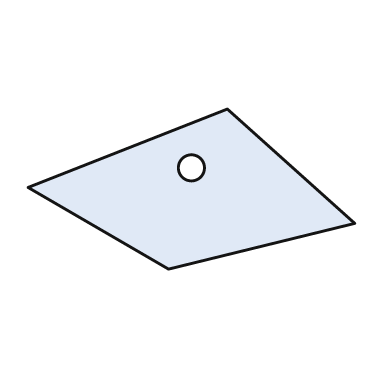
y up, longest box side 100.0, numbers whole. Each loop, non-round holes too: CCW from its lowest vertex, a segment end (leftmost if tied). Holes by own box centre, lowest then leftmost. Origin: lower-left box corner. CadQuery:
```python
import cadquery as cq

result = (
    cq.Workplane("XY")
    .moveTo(43.0, 0.0)
    .lineTo(100.0, 14.0)
    .lineTo(61.0, 49.0)
    .lineTo(0.0, 25.0)
    .close()
    .moveTo(50.0, 31.0)
    .circle(4.0)
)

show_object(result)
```